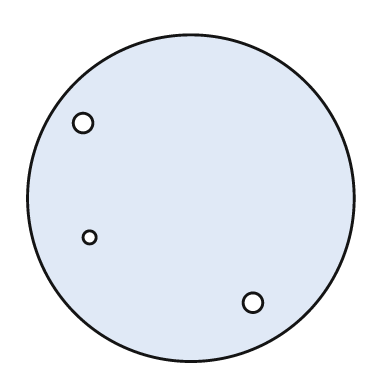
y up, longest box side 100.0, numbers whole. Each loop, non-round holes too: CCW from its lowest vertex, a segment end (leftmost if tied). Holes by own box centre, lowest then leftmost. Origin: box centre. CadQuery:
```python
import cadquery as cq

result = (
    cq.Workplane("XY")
    .moveTo(0.0, 0.0)
    .circle(50.0)
    .moveTo(19.0, -32.0)
    .circle(3.0)
    .moveTo(-31.0, -12.0)
    .circle(2.0)
    .moveTo(-33.0, 23.0)
    .circle(3.0)
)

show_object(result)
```